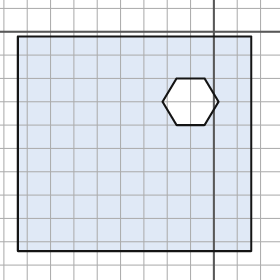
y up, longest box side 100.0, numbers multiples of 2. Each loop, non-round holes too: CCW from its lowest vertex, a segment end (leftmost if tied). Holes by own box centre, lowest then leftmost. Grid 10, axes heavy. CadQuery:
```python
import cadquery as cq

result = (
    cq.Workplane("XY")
    .moveTo(-84.0, -94.0)
    .lineTo(16.0, -94.0)
    .lineTo(16.0, -2.0)
    .lineTo(-84.0, -2.0)
    .close()
    .moveTo(-16.0, -40.0)
    .lineTo(-4.0, -40.0)
    .lineTo(2.0, -30.0)
    .lineTo(-4.0, -20.0)
    .lineTo(-16.0, -20.0)
    .lineTo(-22.0, -30.0)
    .close()
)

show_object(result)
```